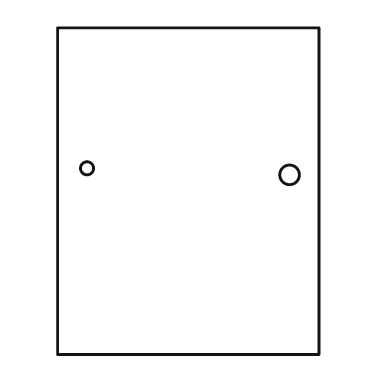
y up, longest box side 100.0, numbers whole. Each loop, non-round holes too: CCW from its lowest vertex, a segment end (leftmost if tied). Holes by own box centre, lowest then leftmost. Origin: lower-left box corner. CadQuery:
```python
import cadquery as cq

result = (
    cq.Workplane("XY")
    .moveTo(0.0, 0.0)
    .lineTo(80.0, 0.0)
    .lineTo(80.0, 100.0)
    .lineTo(0.0, 100.0)
    .close()
    .moveTo(71.0, 55.0)
    .circle(3.0)
    .moveTo(9.0, 57.0)
    .circle(2.0)
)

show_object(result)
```